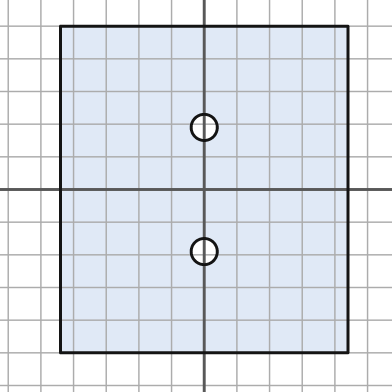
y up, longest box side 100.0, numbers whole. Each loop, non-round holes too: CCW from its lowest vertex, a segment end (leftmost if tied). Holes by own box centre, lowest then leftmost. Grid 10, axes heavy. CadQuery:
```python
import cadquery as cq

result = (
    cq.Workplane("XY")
    .moveTo(-44.0, -50.0)
    .lineTo(44.0, -50.0)
    .lineTo(44.0, 50.0)
    .lineTo(-44.0, 50.0)
    .close()
    .moveTo(0.0, -19.0)
    .circle(4.0)
    .moveTo(0.0, 19.0)
    .circle(4.0)
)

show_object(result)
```